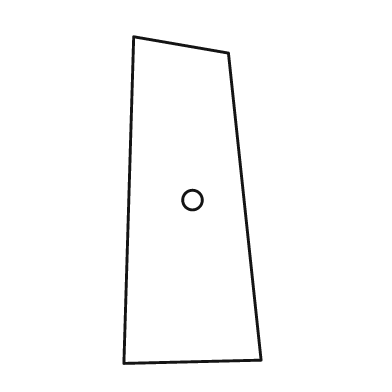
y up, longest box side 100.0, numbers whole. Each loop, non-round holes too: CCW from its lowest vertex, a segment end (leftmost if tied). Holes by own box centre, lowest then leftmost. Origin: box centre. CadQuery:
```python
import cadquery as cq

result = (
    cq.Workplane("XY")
    .moveTo(-21.0, -50.0)
    .lineTo(21.0, -49.0)
    .lineTo(11.0, 45.0)
    .lineTo(-18.0, 50.0)
    .close()
    .moveTo(0.0, 0.0)
    .circle(3.0)
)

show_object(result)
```